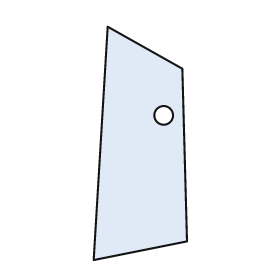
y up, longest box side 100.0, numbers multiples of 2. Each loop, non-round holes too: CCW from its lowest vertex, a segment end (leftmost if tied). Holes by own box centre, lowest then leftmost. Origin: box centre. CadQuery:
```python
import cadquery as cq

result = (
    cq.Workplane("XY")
    .moveTo(-20.0, -50.0)
    .lineTo(20.0, -42.0)
    .lineTo(18.0, 32.0)
    .lineTo(-14.0, 50.0)
    .close()
    .moveTo(10.0, 12.0)
    .circle(4.0)
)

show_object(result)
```